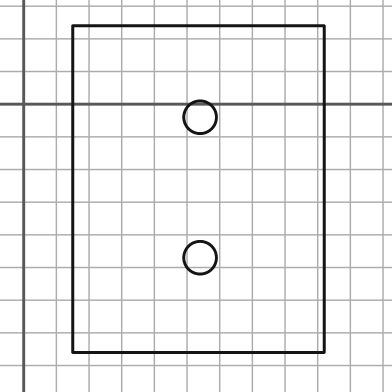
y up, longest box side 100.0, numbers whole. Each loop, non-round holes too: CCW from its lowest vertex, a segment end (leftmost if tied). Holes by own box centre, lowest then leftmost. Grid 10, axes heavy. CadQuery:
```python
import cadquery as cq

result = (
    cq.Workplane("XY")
    .moveTo(15.0, -76.0)
    .lineTo(92.0, -76.0)
    .lineTo(92.0, 24.0)
    .lineTo(15.0, 24.0)
    .close()
    .moveTo(54.0, -47.0)
    .circle(5.0)
    .moveTo(54.0, -4.0)
    .circle(5.0)
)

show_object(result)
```